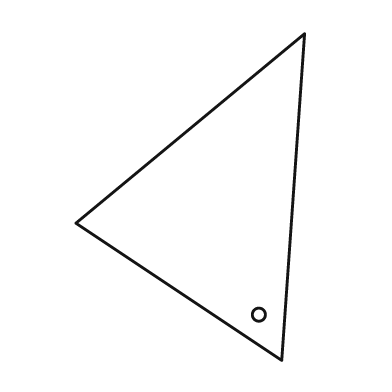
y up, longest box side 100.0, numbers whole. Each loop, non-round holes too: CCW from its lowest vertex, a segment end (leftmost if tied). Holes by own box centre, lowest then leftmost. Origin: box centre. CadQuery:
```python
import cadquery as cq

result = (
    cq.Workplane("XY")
    .moveTo(28.0, -50.0)
    .lineTo(35.0, 50.0)
    .lineTo(-35.0, -8.0)
    .close()
    .moveTo(21.0, -36.0)
    .circle(2.0)
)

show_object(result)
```